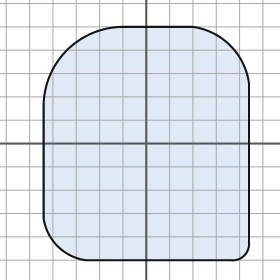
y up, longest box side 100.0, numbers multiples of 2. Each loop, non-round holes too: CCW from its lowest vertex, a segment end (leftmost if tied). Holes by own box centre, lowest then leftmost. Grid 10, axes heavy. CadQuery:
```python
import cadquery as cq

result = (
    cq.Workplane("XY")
    .moveTo(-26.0, -50.0)
    .lineTo(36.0, -50.0)
    .threePointArc((42.0, -48.0), (44.0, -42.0))
    .lineTo(44.0, 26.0)
    .threePointArc((36.0, 42.0), (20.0, 50.0))
    .lineTo(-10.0, 50.0)
    .threePointArc((-34.0, 40.0), (-44.0, 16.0))
    .lineTo(-44.0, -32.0)
    .threePointArc((-38.0, -44.0), (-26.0, -50.0))
    .close()
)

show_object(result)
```